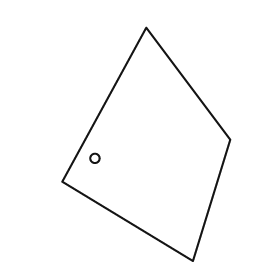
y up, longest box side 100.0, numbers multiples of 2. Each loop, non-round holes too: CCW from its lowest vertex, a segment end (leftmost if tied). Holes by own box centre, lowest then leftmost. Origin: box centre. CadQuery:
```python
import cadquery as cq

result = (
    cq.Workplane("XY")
    .moveTo(20.0, -50.0)
    .lineTo(36.0, 2.0)
    .lineTo(0.0, 50.0)
    .lineTo(-36.0, -16.0)
    .close()
    .moveTo(-22.0, -6.0)
    .circle(2.0)
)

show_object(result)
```